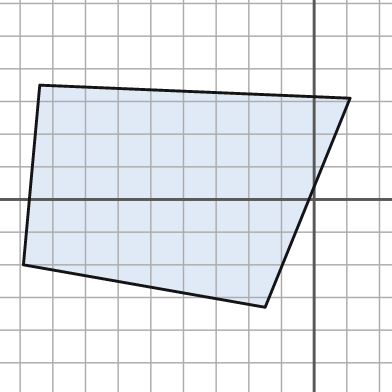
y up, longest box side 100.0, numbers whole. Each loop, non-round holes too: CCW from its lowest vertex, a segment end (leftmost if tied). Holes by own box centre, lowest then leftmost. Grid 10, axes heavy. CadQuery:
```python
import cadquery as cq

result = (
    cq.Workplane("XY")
    .moveTo(-15.0, -33.0)
    .lineTo(11.0, 31.0)
    .lineTo(-84.0, 35.0)
    .lineTo(-89.0, -20.0)
    .close()
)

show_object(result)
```